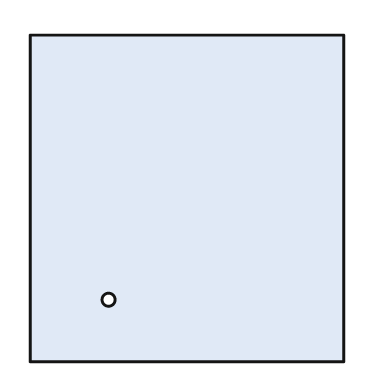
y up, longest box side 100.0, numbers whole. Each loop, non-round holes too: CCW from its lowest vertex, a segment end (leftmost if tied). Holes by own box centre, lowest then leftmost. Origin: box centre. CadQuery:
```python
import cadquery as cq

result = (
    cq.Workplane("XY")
    .moveTo(-48.0, -50.0)
    .lineTo(48.0, -50.0)
    .lineTo(48.0, 50.0)
    .lineTo(-48.0, 50.0)
    .close()
    .moveTo(-24.0, -31.0)
    .circle(2.0)
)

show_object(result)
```